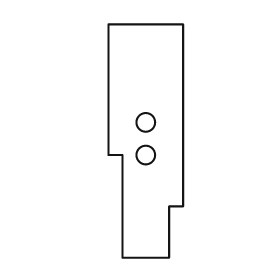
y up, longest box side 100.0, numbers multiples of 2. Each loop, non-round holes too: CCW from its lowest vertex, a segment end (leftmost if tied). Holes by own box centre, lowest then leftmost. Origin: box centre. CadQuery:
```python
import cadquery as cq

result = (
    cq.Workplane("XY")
    .moveTo(-10.0, -50.0)
    .lineTo(10.0, -50.0)
    .lineTo(10.0, -28.0)
    .lineTo(16.0, -28.0)
    .lineTo(16.0, 50.0)
    .lineTo(-16.0, 50.0)
    .lineTo(-16.0, -6.0)
    .lineTo(-10.0, -6.0)
    .close()
    .moveTo(0.0, -6.0)
    .circle(4.0)
    .moveTo(0.0, 8.0)
    .circle(4.0)
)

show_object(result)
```